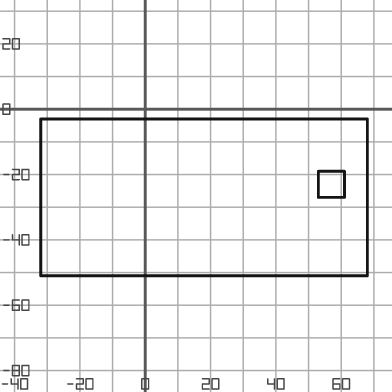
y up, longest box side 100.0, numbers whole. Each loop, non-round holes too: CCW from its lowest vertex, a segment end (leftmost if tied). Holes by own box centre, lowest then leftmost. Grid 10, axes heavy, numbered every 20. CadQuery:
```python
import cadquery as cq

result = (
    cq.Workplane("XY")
    .moveTo(-32.0, -51.0)
    .lineTo(68.0, -51.0)
    .lineTo(68.0, -3.0)
    .lineTo(-32.0, -3.0)
    .close()
    .moveTo(53.0, -27.0)
    .lineTo(61.0, -27.0)
    .lineTo(61.0, -19.0)
    .lineTo(53.0, -19.0)
    .close()
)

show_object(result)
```